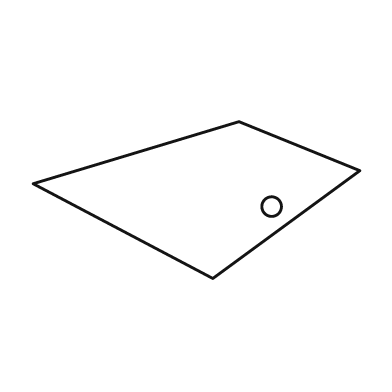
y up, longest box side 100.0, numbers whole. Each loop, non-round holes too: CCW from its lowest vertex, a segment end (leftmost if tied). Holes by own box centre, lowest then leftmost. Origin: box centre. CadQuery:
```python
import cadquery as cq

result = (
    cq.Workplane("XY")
    .moveTo(5.0, -24.0)
    .lineTo(50.0, 9.0)
    .lineTo(13.0, 24.0)
    .lineTo(-50.0, 5.0)
    .close()
    .moveTo(23.0, -2.0)
    .circle(3.0)
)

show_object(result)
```